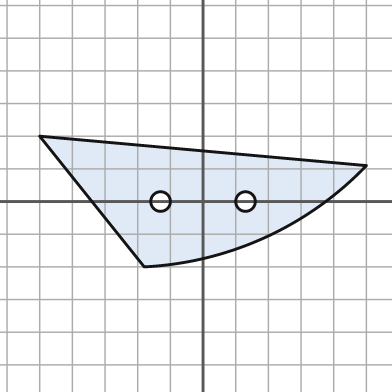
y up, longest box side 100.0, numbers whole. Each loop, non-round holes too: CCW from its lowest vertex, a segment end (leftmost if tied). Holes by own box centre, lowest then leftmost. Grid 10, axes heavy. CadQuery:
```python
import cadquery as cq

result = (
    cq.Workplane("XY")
    .moveTo(-18.0, -20.0)
    .threePointArc((19.0, -11.0), (50.0, 11.0))
    .lineTo(-50.0, 20.0)
    .close()
    .moveTo(-13.0, 0.0)
    .circle(3.0)
    .moveTo(13.0, 0.0)
    .circle(3.0)
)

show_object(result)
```